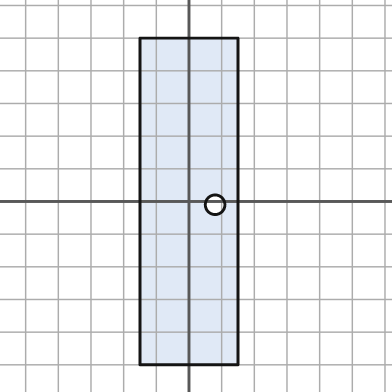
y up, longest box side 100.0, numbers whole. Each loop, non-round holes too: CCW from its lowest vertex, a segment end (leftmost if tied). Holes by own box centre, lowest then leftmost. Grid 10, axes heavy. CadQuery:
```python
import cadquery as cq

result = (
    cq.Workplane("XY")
    .moveTo(-15.0, -50.0)
    .lineTo(15.0, -50.0)
    .lineTo(15.0, 50.0)
    .lineTo(-15.0, 50.0)
    .close()
    .moveTo(8.0, -1.0)
    .circle(3.0)
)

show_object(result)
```